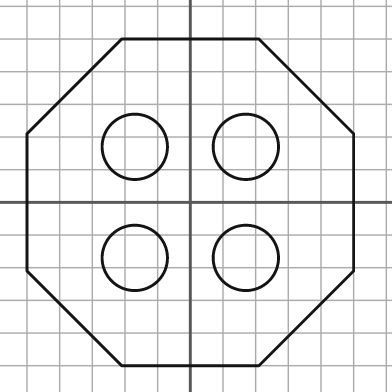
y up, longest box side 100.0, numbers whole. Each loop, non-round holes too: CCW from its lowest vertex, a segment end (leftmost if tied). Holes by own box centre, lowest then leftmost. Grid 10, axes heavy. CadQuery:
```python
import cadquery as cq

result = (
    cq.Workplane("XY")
    .moveTo(-21.0, -50.0)
    .lineTo(21.0, -50.0)
    .lineTo(50.0, -21.0)
    .lineTo(50.0, 21.0)
    .lineTo(21.0, 50.0)
    .lineTo(-21.0, 50.0)
    .lineTo(-50.0, 21.0)
    .lineTo(-50.0, -21.0)
    .close()
    .moveTo(-17.0, -17.0)
    .circle(10.0)
    .moveTo(17.0, -17.0)
    .circle(10.0)
    .moveTo(-17.0, 17.0)
    .circle(10.0)
    .moveTo(17.0, 17.0)
    .circle(10.0)
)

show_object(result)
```